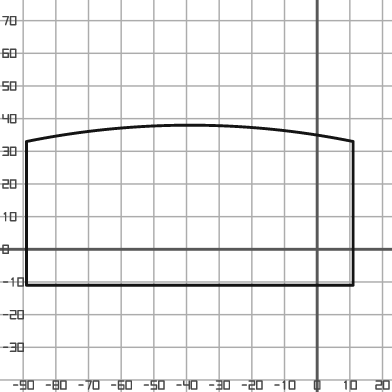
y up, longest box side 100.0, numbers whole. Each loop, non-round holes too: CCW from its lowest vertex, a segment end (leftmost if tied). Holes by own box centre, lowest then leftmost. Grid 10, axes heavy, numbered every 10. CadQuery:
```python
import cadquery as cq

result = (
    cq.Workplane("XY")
    .moveTo(-89.0, -11.0)
    .lineTo(11.0, -11.0)
    .lineTo(11.0, 33.0)
    .threePointArc((-39.0, 38.0), (-89.0, 33.0))
    .close()
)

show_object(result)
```